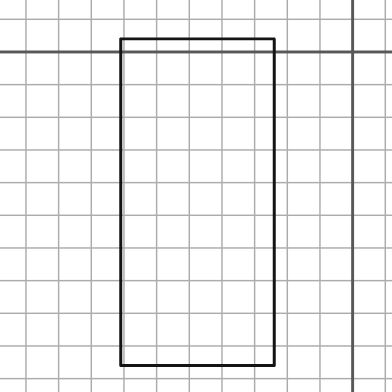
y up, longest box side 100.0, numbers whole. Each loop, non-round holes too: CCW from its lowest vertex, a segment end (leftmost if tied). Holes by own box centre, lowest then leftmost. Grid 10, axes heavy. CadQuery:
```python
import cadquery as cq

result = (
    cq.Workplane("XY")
    .moveTo(-71.0, -96.0)
    .lineTo(-24.0, -96.0)
    .lineTo(-24.0, 4.0)
    .lineTo(-71.0, 4.0)
    .close()
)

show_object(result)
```